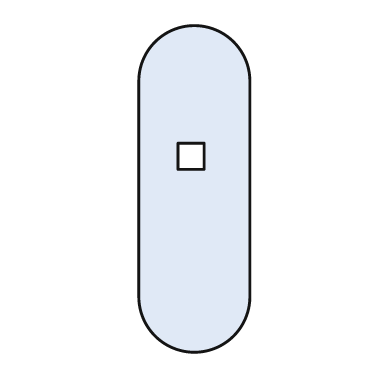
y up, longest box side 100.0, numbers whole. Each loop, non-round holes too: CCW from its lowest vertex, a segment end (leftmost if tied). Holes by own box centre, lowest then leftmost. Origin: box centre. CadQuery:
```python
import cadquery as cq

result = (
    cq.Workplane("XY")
    .moveTo(-17.0, -33.0)
    .threePointArc((0.0, -50.0), (17.0, -33.0))
    .lineTo(17.0, 33.0)
    .threePointArc((0.0, 50.0), (-17.0, 33.0))
    .close()
    .moveTo(-5.0, 6.0)
    .lineTo(3.0, 6.0)
    .lineTo(3.0, 14.0)
    .lineTo(-5.0, 14.0)
    .close()
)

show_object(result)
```